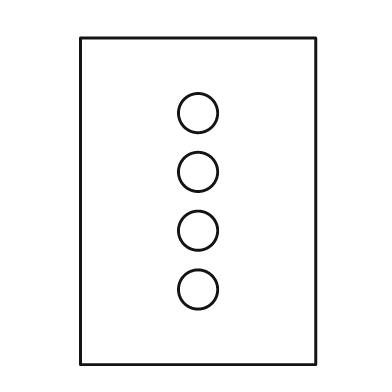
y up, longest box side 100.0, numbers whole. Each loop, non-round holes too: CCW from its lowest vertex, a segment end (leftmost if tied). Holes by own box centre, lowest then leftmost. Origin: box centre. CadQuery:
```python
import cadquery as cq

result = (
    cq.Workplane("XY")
    .moveTo(-36.0, -50.0)
    .lineTo(36.0, -50.0)
    .lineTo(36.0, 50.0)
    .lineTo(-36.0, 50.0)
    .close()
    .moveTo(0.0, -27.0)
    .circle(6.0)
    .moveTo(0.0, -9.0)
    .circle(6.0)
    .moveTo(0.0, 9.0)
    .circle(6.0)
    .moveTo(0.0, 27.0)
    .circle(6.0)
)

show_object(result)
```